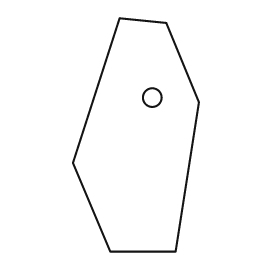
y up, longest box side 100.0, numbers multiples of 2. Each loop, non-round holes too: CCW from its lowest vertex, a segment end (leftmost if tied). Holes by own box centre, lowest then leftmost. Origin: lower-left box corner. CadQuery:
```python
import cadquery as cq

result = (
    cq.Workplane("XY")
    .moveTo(16.0, 0.0)
    .lineTo(44.0, 0.0)
    .lineTo(54.0, 64.0)
    .lineTo(40.0, 98.0)
    .lineTo(20.0, 100.0)
    .lineTo(0.0, 38.0)
    .close()
    .moveTo(34.0, 66.0)
    .circle(4.0)
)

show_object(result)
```